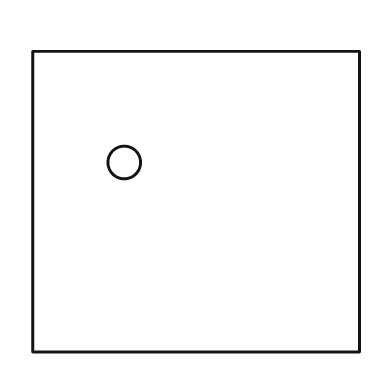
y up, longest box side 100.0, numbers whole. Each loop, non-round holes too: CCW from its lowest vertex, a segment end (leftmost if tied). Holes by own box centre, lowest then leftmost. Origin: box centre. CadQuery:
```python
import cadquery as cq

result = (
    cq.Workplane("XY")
    .moveTo(-50.0, -46.0)
    .lineTo(50.0, -46.0)
    .lineTo(50.0, 46.0)
    .lineTo(-50.0, 46.0)
    .close()
    .moveTo(-22.0, 12.0)
    .circle(5.0)
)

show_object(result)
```